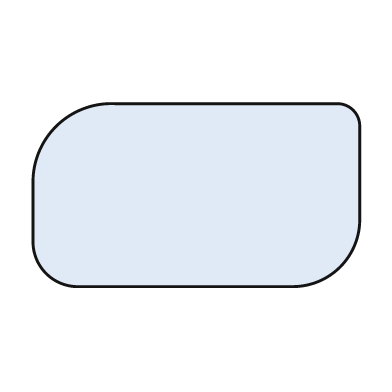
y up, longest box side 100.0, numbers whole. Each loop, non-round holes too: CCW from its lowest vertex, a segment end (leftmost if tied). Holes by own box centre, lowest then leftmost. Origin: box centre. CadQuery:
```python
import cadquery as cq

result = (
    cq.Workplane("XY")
    .moveTo(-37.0, -28.0)
    .lineTo(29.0, -28.0)
    .threePointArc((44.0, -22.0), (50.0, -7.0))
    .lineTo(50.0, 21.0)
    .threePointArc((48.0, 26.0), (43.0, 28.0))
    .lineTo(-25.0, 28.0)
    .threePointArc((-43.0, 21.0), (-50.0, 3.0))
    .lineTo(-50.0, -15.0)
    .threePointArc((-46.0, -24.0), (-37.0, -28.0))
    .close()
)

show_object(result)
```